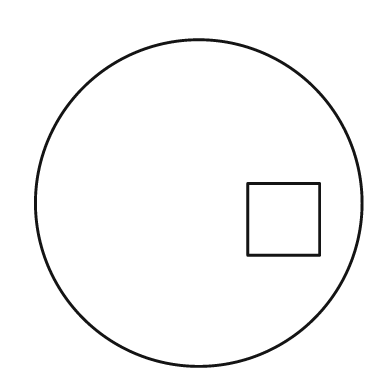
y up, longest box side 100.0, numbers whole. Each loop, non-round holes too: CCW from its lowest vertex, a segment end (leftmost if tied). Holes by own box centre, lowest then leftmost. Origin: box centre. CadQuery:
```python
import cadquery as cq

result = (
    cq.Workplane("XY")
    .moveTo(0.0, 0.0)
    .circle(50.0)
    .moveTo(15.0, -16.0)
    .lineTo(37.0, -16.0)
    .lineTo(37.0, 6.0)
    .lineTo(15.0, 6.0)
    .close()
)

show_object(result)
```